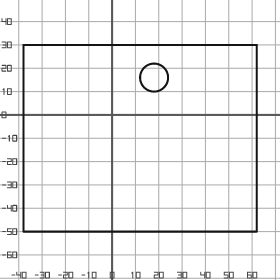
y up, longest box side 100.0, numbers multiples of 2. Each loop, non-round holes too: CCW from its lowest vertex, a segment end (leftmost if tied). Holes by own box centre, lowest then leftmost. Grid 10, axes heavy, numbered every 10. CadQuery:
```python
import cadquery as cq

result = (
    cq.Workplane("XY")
    .moveTo(-38.0, -50.0)
    .lineTo(62.0, -50.0)
    .lineTo(62.0, 30.0)
    .lineTo(-38.0, 30.0)
    .close()
    .moveTo(18.0, 16.0)
    .circle(6.0)
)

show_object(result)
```